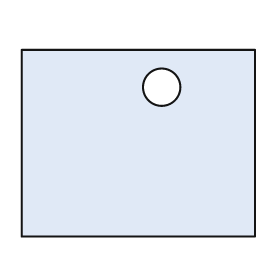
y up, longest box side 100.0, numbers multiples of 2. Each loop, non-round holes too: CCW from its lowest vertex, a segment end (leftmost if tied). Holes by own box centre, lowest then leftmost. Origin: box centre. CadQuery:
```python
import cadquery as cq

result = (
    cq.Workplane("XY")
    .moveTo(-50.0, -40.0)
    .lineTo(50.0, -40.0)
    .lineTo(50.0, 40.0)
    .lineTo(-50.0, 40.0)
    .close()
    .moveTo(10.0, 24.0)
    .circle(8.0)
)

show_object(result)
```